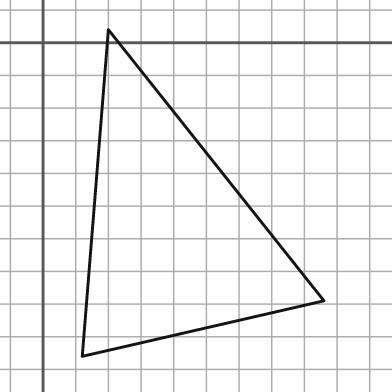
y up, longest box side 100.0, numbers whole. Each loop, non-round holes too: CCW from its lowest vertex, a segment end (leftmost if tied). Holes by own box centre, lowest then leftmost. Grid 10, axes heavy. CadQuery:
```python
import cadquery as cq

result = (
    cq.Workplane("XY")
    .moveTo(12.0, -96.0)
    .lineTo(86.0, -79.0)
    .lineTo(20.0, 4.0)
    .close()
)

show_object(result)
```